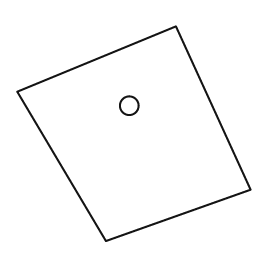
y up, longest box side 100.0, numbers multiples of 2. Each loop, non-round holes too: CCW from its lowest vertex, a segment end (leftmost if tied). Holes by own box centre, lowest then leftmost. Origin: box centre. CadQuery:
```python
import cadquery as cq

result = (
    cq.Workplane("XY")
    .moveTo(-12.0, -46.0)
    .lineTo(50.0, -24.0)
    .lineTo(18.0, 46.0)
    .lineTo(-50.0, 18.0)
    .close()
    .moveTo(-2.0, 12.0)
    .circle(4.0)
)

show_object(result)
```